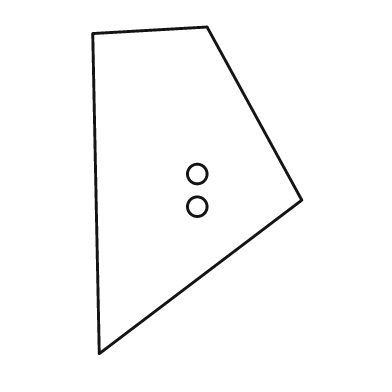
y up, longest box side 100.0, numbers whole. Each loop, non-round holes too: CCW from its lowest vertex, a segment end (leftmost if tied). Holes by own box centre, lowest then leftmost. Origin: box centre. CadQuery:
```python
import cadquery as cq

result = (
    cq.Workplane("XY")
    .moveTo(-30.0, -50.0)
    .lineTo(32.0, -3.0)
    .lineTo(3.0, 50.0)
    .lineTo(-32.0, 48.0)
    .close()
    .moveTo(0.0, -5.0)
    .circle(3.0)
    .moveTo(0.0, 5.0)
    .circle(3.0)
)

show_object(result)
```